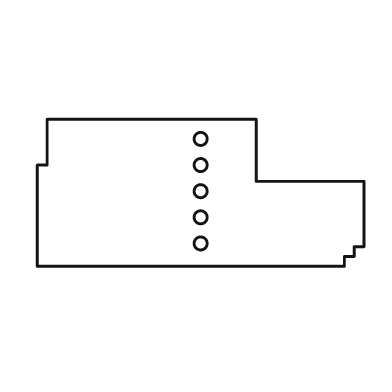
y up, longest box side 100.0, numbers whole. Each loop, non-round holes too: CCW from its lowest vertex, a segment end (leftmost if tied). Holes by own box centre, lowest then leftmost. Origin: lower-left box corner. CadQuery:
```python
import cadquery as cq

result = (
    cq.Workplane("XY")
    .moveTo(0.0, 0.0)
    .lineTo(94.0, 0.0)
    .lineTo(94.0, 3.0)
    .lineTo(97.0, 3.0)
    .lineTo(97.0, 6.0)
    .lineTo(100.0, 6.0)
    .lineTo(100.0, 26.0)
    .lineTo(67.0, 26.0)
    .lineTo(67.0, 45.0)
    .lineTo(3.0, 45.0)
    .lineTo(3.0, 31.0)
    .lineTo(0.0, 31.0)
    .close()
    .moveTo(50.0, 7.0)
    .circle(2.0)
    .moveTo(50.0, 15.0)
    .circle(2.0)
    .moveTo(50.0, 23.0)
    .circle(2.0)
    .moveTo(50.0, 31.0)
    .circle(2.0)
    .moveTo(50.0, 39.0)
    .circle(2.0)
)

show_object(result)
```